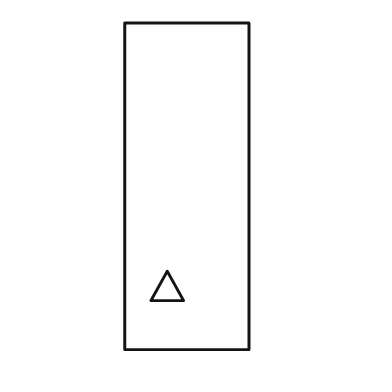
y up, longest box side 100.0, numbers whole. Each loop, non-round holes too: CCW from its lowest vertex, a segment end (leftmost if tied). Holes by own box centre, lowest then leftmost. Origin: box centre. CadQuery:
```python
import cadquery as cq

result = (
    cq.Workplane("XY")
    .moveTo(-19.0, -50.0)
    .lineTo(19.0, -50.0)
    .lineTo(19.0, 50.0)
    .lineTo(-19.0, 50.0)
    .close()
    .moveTo(-11.0, -35.0)
    .lineTo(-1.0, -35.0)
    .lineTo(-6.0, -26.0)
    .close()
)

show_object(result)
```